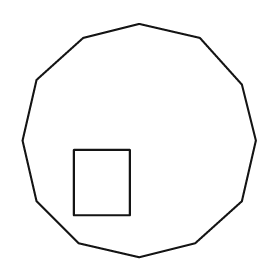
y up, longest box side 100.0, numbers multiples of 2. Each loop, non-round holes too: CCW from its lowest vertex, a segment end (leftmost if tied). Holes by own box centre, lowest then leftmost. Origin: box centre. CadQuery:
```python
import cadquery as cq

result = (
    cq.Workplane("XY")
    .moveTo(0.0, -50.0)
    .lineTo(24.0, -44.0)
    .lineTo(44.0, -26.0)
    .lineTo(50.0, 0.0)
    .lineTo(44.0, 24.0)
    .lineTo(26.0, 44.0)
    .lineTo(0.0, 50.0)
    .lineTo(-24.0, 44.0)
    .lineTo(-44.0, 26.0)
    .lineTo(-50.0, 0.0)
    .lineTo(-44.0, -26.0)
    .lineTo(-26.0, -44.0)
    .close()
    .moveTo(-28.0, -32.0)
    .lineTo(-4.0, -32.0)
    .lineTo(-4.0, -4.0)
    .lineTo(-28.0, -4.0)
    .close()
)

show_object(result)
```